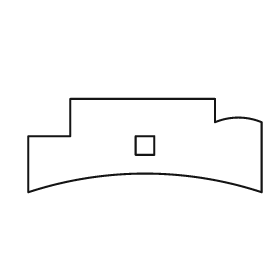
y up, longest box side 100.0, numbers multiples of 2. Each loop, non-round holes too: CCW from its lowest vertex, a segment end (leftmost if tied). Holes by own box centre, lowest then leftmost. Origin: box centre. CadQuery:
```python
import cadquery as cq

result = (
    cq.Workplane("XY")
    .moveTo(-50.0, -20.0)
    .threePointArc((0.0, -12.0), (50.0, -20.0))
    .lineTo(50.0, 10.0)
    .threePointArc((40.0, 12.0), (30.0, 10.0))
    .lineTo(30.0, 20.0)
    .lineTo(-32.0, 20.0)
    .lineTo(-32.0, 4.0)
    .lineTo(-50.0, 4.0)
    .close()
    .moveTo(-4.0, -4.0)
    .lineTo(4.0, -4.0)
    .lineTo(4.0, 4.0)
    .lineTo(-4.0, 4.0)
    .close()
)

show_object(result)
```